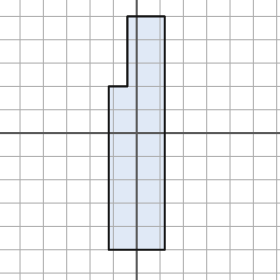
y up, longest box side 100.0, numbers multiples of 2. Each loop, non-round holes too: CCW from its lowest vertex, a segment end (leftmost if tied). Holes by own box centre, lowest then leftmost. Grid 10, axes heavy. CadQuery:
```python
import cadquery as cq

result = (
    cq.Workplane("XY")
    .moveTo(-12.0, -50.0)
    .lineTo(12.0, -50.0)
    .lineTo(12.0, 50.0)
    .lineTo(-4.0, 50.0)
    .lineTo(-4.0, 20.0)
    .lineTo(-12.0, 20.0)
    .close()
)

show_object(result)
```